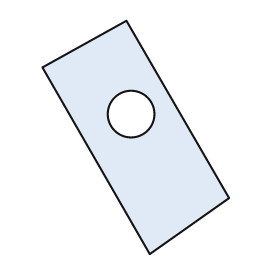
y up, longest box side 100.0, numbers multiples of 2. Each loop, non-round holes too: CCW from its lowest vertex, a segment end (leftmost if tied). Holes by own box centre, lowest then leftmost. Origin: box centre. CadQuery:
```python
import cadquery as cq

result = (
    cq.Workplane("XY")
    .moveTo(6.0, -50.0)
    .lineTo(40.0, -26.0)
    .lineTo(-4.0, 50.0)
    .lineTo(-40.0, 30.0)
    .close()
    .moveTo(-2.0, 10.0)
    .circle(10.0)
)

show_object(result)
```